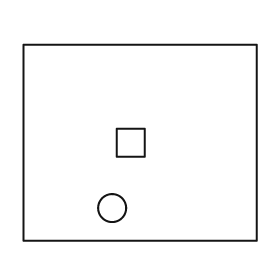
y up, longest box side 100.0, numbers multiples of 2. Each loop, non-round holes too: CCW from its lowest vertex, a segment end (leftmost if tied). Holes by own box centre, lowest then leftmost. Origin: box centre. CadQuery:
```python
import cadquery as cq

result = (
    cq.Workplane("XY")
    .moveTo(-50.0, -42.0)
    .lineTo(50.0, -42.0)
    .lineTo(50.0, 42.0)
    .lineTo(-50.0, 42.0)
    .close()
    .moveTo(-12.0, -28.0)
    .circle(6.0)
    .moveTo(-10.0, -6.0)
    .lineTo(2.0, -6.0)
    .lineTo(2.0, 6.0)
    .lineTo(-10.0, 6.0)
    .close()
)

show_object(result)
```